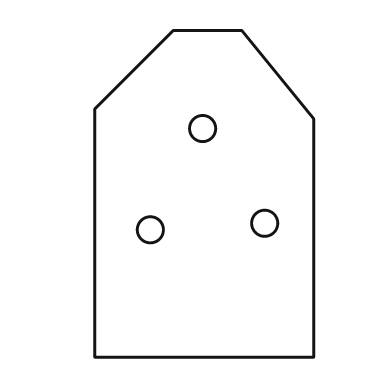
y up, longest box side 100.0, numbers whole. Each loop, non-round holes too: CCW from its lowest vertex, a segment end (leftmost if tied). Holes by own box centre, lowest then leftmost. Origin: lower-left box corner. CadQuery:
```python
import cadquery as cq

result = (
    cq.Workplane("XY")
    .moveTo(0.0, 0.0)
    .lineTo(67.0, 0.0)
    .lineTo(67.0, 73.0)
    .lineTo(45.0, 100.0)
    .lineTo(24.0, 100.0)
    .lineTo(0.0, 76.0)
    .close()
    .moveTo(17.0, 39.0)
    .circle(4.0)
    .moveTo(52.0, 41.0)
    .circle(4.0)
    .moveTo(33.0, 70.0)
    .circle(4.0)
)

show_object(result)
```